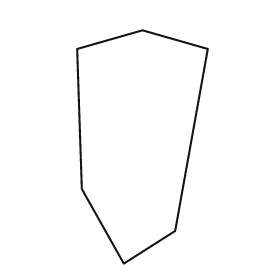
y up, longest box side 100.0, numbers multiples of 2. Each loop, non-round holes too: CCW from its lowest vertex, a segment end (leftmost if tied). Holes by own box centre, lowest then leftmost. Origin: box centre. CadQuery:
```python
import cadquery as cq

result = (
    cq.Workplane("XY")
    .moveTo(-8.0, -50.0)
    .lineTo(14.0, -36.0)
    .lineTo(28.0, 42.0)
    .lineTo(0.0, 50.0)
    .lineTo(-28.0, 42.0)
    .lineTo(-26.0, -18.0)
    .close()
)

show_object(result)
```